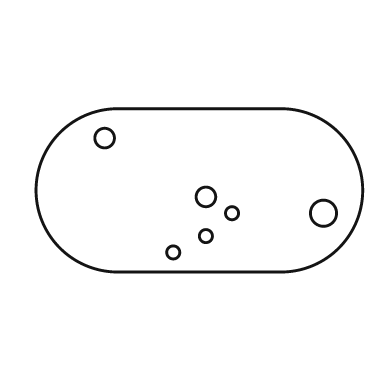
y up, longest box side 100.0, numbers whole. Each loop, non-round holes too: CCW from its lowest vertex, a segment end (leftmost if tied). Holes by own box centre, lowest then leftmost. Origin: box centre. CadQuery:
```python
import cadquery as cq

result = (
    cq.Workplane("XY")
    .moveTo(-25.0, -25.0)
    .lineTo(25.0, -25.0)
    .threePointArc((50.0, 0.0), (25.0, 25.0))
    .lineTo(-25.0, 25.0)
    .threePointArc((-50.0, 0.0), (-25.0, -25.0))
    .close()
    .moveTo(-8.0, -19.0)
    .circle(2.0)
    .moveTo(2.0, -14.0)
    .circle(2.0)
    .moveTo(10.0, -7.0)
    .circle(2.0)
    .moveTo(38.0, -7.0)
    .circle(4.0)
    .moveTo(2.0, -2.0)
    .circle(3.0)
    .moveTo(-29.0, 16.0)
    .circle(3.0)
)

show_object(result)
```